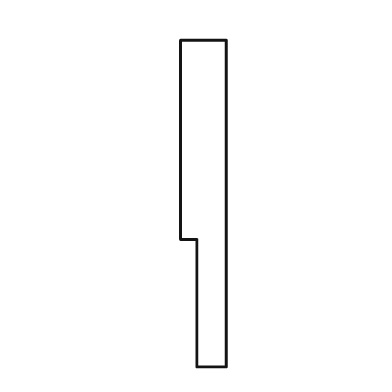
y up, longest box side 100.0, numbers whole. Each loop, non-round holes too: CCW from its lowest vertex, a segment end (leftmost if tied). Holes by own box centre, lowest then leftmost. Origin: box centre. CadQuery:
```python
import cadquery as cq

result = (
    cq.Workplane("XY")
    .moveTo(-2.0, -50.0)
    .lineTo(7.0, -50.0)
    .lineTo(7.0, 50.0)
    .lineTo(-7.0, 50.0)
    .lineTo(-7.0, -11.0)
    .lineTo(-2.0, -11.0)
    .close()
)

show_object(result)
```